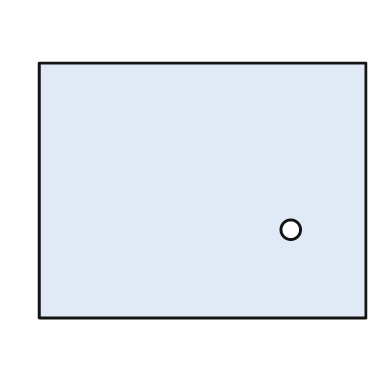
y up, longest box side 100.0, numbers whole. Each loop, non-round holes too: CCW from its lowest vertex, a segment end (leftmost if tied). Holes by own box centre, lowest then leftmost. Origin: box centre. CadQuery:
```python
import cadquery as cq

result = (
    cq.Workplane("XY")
    .moveTo(-50.0, -39.0)
    .lineTo(50.0, -39.0)
    .lineTo(50.0, 39.0)
    .lineTo(-50.0, 39.0)
    .close()
    .moveTo(27.0, -12.0)
    .circle(3.0)
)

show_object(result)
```